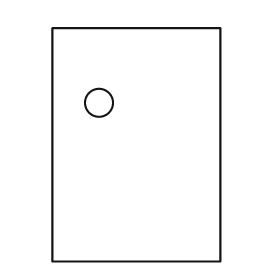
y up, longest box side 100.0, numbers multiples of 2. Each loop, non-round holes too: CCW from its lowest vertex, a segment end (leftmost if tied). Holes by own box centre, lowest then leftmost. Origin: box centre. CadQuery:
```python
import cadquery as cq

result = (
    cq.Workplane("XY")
    .moveTo(-36.0, -50.0)
    .lineTo(36.0, -50.0)
    .lineTo(36.0, 50.0)
    .lineTo(-36.0, 50.0)
    .close()
    .moveTo(-16.0, 18.0)
    .circle(6.0)
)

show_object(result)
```